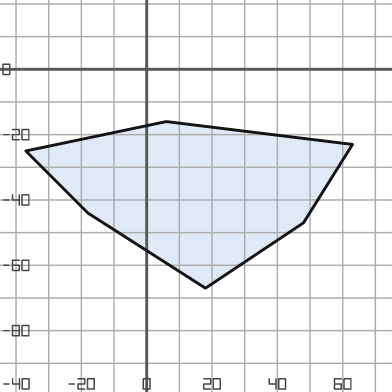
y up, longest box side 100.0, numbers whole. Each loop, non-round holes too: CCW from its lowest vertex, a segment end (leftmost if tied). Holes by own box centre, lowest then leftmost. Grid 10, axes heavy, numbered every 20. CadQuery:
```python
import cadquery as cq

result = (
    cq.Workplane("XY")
    .moveTo(18.0, -67.0)
    .lineTo(48.0, -47.0)
    .lineTo(63.0, -23.0)
    .lineTo(6.0, -16.0)
    .lineTo(-37.0, -25.0)
    .lineTo(-18.0, -44.0)
    .close()
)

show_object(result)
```